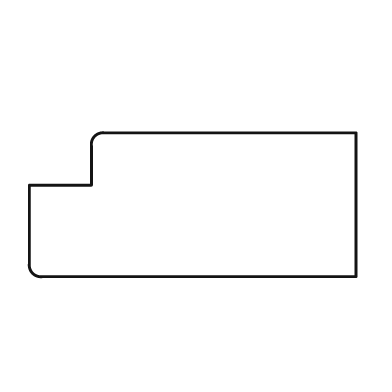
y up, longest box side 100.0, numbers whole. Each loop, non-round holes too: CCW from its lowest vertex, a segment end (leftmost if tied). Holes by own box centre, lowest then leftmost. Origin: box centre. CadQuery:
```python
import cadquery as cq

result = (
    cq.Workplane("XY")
    .moveTo(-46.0, -22.0)
    .lineTo(50.0, -22.0)
    .lineTo(50.0, 22.0)
    .lineTo(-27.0, 22.0)
    .threePointArc((-30.0, 21.0), (-31.0, 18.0))
    .lineTo(-31.0, 6.0)
    .lineTo(-50.0, 6.0)
    .lineTo(-50.0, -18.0)
    .threePointArc((-49.0, -21.0), (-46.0, -22.0))
    .close()
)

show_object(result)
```